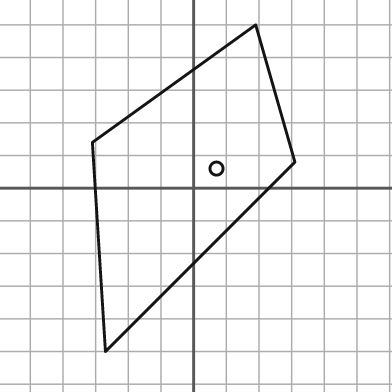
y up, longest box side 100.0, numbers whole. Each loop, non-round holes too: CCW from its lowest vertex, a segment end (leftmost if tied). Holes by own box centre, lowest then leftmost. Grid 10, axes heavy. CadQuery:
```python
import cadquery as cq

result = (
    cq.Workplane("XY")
    .moveTo(-27.0, -50.0)
    .lineTo(31.0, 8.0)
    .lineTo(19.0, 50.0)
    .lineTo(-31.0, 14.0)
    .close()
    .moveTo(7.0, 6.0)
    .circle(2.0)
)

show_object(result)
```